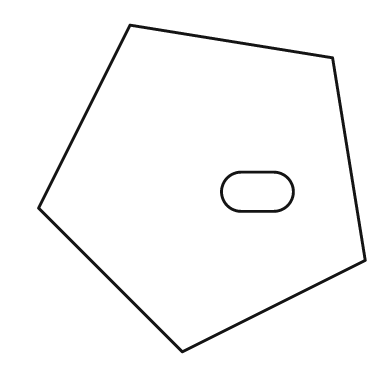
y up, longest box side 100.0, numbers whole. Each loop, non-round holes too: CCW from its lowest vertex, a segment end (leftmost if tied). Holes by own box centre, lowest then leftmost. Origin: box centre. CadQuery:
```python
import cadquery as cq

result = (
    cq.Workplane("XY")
    .moveTo(-6.0, -50.0)
    .lineTo(50.0, -22.0)
    .lineTo(40.0, 40.0)
    .lineTo(-22.0, 50.0)
    .lineTo(-50.0, -6.0)
    .close()
    .moveTo(12.0, -7.0)
    .lineTo(22.0, -7.0)
    .threePointArc((28.0, -1.0), (22.0, 5.0))
    .lineTo(12.0, 5.0)
    .threePointArc((6.0, -1.0), (12.0, -7.0))
    .close()
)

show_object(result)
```